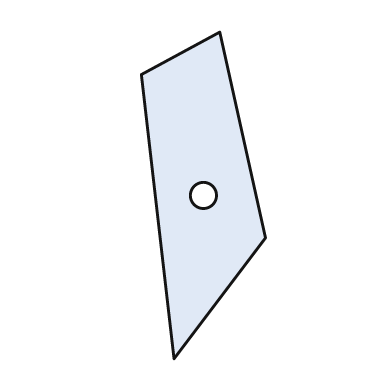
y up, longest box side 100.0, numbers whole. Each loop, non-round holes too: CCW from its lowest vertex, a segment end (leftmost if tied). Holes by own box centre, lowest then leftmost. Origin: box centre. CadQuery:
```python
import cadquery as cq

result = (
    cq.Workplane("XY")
    .moveTo(-9.0, -50.0)
    .lineTo(19.0, -13.0)
    .lineTo(5.0, 50.0)
    .lineTo(-19.0, 37.0)
    .close()
    .moveTo(0.0, 0.0)
    .circle(4.0)
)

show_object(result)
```